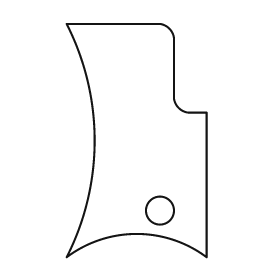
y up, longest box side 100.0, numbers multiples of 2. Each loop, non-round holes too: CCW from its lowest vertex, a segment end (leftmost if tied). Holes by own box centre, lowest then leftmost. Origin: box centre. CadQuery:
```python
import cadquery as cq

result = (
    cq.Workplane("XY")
    .moveTo(-30.0, -50.0)
    .threePointArc((0.0, -40.0), (30.0, -50.0))
    .lineTo(30.0, 12.0)
    .lineTo(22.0, 12.0)
    .threePointArc((18.0, 14.0), (16.0, 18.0))
    .lineTo(16.0, 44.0)
    .threePointArc((14.0, 48.0), (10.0, 50.0))
    .lineTo(-30.0, 50.0)
    .threePointArc((-18.0, 0.0), (-30.0, -50.0))
    .close()
    .moveTo(10.0, -30.0)
    .circle(6.0)
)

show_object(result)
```